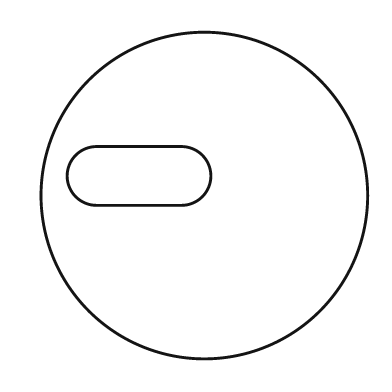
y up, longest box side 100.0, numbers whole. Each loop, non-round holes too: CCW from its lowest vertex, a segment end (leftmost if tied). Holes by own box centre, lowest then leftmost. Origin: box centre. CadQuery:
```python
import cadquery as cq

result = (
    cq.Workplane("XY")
    .moveTo(0.0, 0.0)
    .circle(50.0)
    .moveTo(-33.0, -3.0)
    .lineTo(-7.0, -3.0)
    .threePointArc((2.0, 6.0), (-7.0, 15.0))
    .lineTo(-33.0, 15.0)
    .threePointArc((-42.0, 6.0), (-33.0, -3.0))
    .close()
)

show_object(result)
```